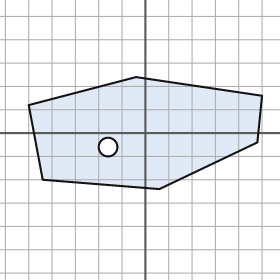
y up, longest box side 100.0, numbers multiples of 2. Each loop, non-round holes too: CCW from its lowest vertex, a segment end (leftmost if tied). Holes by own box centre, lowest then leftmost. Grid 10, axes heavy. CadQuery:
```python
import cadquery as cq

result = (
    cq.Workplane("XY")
    .moveTo(6.0, -24.0)
    .lineTo(48.0, -4.0)
    .lineTo(50.0, 16.0)
    .lineTo(-4.0, 24.0)
    .lineTo(-50.0, 12.0)
    .lineTo(-44.0, -20.0)
    .close()
    .moveTo(-16.0, -6.0)
    .circle(4.0)
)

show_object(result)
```